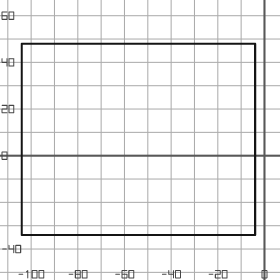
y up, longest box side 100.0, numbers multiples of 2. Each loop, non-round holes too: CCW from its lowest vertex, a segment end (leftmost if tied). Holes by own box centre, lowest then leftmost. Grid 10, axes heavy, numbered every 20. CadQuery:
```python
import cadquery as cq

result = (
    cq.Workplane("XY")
    .moveTo(-104.0, -34.0)
    .lineTo(-4.0, -34.0)
    .lineTo(-4.0, 48.0)
    .lineTo(-104.0, 48.0)
    .close()
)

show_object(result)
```